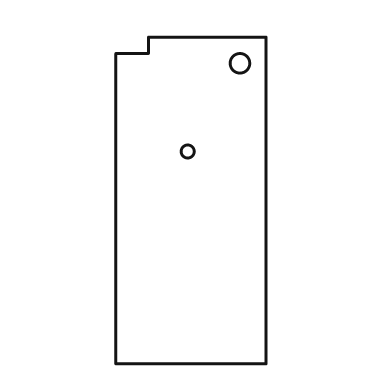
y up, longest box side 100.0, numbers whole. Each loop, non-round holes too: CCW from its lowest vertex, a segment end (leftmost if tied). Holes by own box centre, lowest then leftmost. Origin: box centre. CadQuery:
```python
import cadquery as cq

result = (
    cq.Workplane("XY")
    .moveTo(-23.0, -50.0)
    .lineTo(23.0, -50.0)
    .lineTo(23.0, 50.0)
    .lineTo(-13.0, 50.0)
    .lineTo(-13.0, 45.0)
    .lineTo(-23.0, 45.0)
    .close()
    .moveTo(-1.0, 15.0)
    .circle(2.0)
    .moveTo(15.0, 42.0)
    .circle(3.0)
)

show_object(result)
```